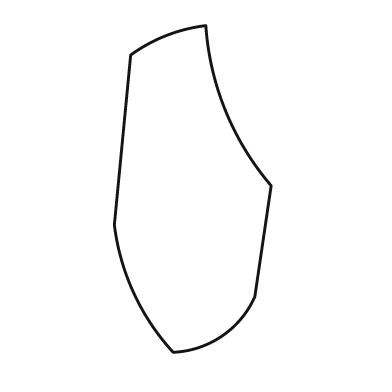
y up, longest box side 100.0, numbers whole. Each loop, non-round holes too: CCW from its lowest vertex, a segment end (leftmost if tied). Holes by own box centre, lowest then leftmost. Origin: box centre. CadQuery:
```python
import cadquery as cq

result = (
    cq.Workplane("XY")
    .moveTo(-6.0, -50.0)
    .threePointArc((9.0, -45.0), (19.0, -33.0))
    .lineTo(24.0, 1.0)
    .threePointArc((10.0, 24.0), (4.0, 50.0))
    .threePointArc((-8.0, 47.0), (-19.0, 41.0))
    .lineTo(-24.0, -11.0)
    .threePointArc((-18.0, -32.0), (-6.0, -50.0))
    .close()
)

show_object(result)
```